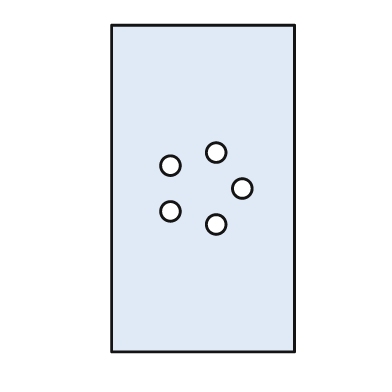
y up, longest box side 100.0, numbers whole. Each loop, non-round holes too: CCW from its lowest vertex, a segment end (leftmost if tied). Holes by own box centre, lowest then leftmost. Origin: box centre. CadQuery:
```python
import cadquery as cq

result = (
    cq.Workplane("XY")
    .moveTo(-28.0, -50.0)
    .lineTo(28.0, -50.0)
    .lineTo(28.0, 50.0)
    .lineTo(-28.0, 50.0)
    .close()
    .moveTo(4.0, -11.0)
    .circle(3.0)
    .moveTo(-10.0, -7.0)
    .circle(3.0)
    .moveTo(12.0, 0.0)
    .circle(3.0)
    .moveTo(-10.0, 7.0)
    .circle(3.0)
    .moveTo(4.0, 11.0)
    .circle(3.0)
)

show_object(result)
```